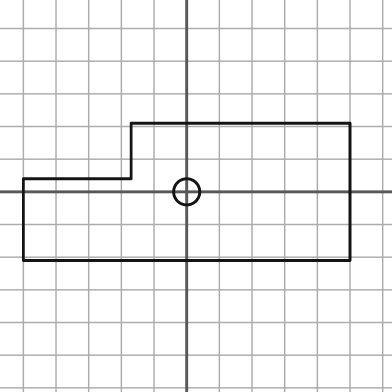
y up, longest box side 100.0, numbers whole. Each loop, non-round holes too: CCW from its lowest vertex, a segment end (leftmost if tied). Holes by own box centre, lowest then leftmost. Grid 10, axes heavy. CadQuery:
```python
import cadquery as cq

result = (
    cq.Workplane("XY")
    .moveTo(-50.0, -21.0)
    .lineTo(50.0, -21.0)
    .lineTo(50.0, 21.0)
    .lineTo(-17.0, 21.0)
    .lineTo(-17.0, 4.0)
    .lineTo(-50.0, 4.0)
    .close()
    .moveTo(0.0, 0.0)
    .circle(4.0)
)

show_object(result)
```